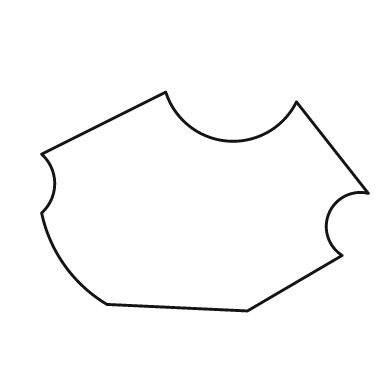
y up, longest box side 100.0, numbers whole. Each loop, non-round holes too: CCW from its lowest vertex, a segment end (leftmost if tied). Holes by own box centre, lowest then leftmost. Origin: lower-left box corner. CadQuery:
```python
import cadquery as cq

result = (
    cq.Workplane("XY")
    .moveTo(63.0, 0.0)
    .lineTo(92.0, 17.0)
    .threePointArc((88.0, 30.0), (100.0, 36.0))
    .lineTo(78.0, 64.0)
    .threePointArc((57.0, 52.0), (38.0, 67.0))
    .lineTo(0.0, 48.0)
    .threePointArc((4.0, 39.0), (0.0, 30.0))
    .threePointArc((7.0, 14.0), (20.0, 2.0))
    .close()
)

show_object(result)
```